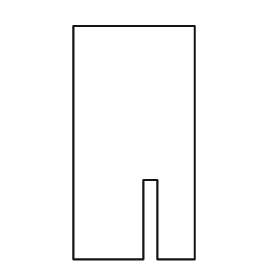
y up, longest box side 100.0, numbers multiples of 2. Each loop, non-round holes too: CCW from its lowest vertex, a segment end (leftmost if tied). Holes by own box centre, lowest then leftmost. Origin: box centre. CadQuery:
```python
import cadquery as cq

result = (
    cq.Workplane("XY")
    .moveTo(-26.0, -50.0)
    .lineTo(4.0, -50.0)
    .lineTo(4.0, -16.0)
    .lineTo(10.0, -16.0)
    .lineTo(10.0, -50.0)
    .lineTo(26.0, -50.0)
    .lineTo(26.0, 50.0)
    .lineTo(-26.0, 50.0)
    .close()
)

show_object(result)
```